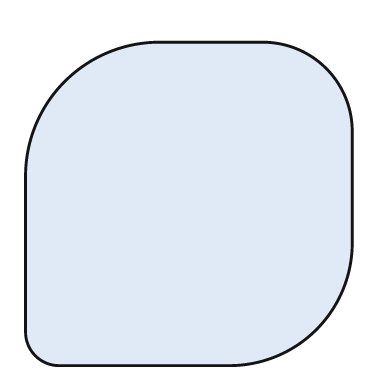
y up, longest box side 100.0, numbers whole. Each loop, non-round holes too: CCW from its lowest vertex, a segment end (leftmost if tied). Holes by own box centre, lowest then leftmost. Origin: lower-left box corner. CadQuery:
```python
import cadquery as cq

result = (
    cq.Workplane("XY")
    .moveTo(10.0, 0.0)
    .lineTo(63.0, 0.0)
    .threePointArc((89.0, 11.0), (100.0, 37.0))
    .lineTo(100.0, 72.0)
    .threePointArc((92.0, 91.0), (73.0, 99.0))
    .lineTo(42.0, 99.0)
    .threePointArc((12.0, 87.0), (0.0, 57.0))
    .lineTo(0.0, 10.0)
    .threePointArc((3.0, 3.0), (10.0, 0.0))
    .close()
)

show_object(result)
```